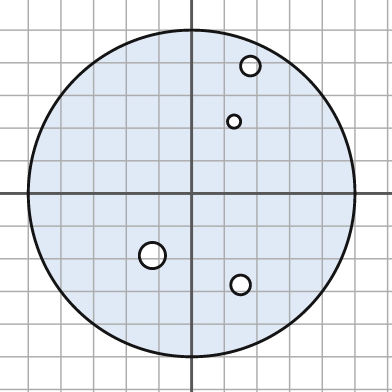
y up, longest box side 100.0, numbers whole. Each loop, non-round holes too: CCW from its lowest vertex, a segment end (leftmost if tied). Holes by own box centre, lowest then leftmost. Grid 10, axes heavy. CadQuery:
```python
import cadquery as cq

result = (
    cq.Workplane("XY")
    .moveTo(0.0, 0.0)
    .circle(50.0)
    .moveTo(15.0, -28.0)
    .circle(3.0)
    .moveTo(-12.0, -19.0)
    .circle(4.0)
    .moveTo(13.0, 22.0)
    .circle(2.0)
    .moveTo(18.0, 39.0)
    .circle(3.0)
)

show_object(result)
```